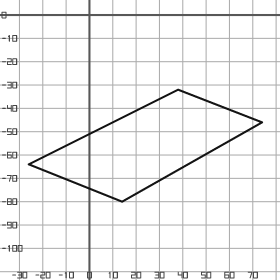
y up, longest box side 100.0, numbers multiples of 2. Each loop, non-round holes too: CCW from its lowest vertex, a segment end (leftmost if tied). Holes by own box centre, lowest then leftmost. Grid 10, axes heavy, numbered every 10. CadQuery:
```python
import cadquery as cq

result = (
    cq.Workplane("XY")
    .moveTo(14.0, -80.0)
    .lineTo(74.0, -46.0)
    .lineTo(38.0, -32.0)
    .lineTo(-26.0, -64.0)
    .close()
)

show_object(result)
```